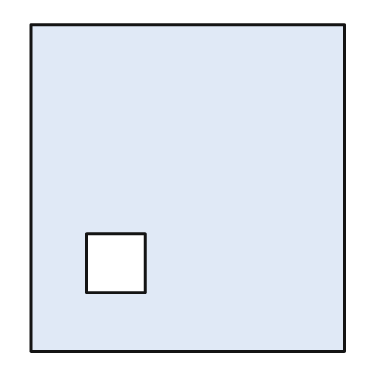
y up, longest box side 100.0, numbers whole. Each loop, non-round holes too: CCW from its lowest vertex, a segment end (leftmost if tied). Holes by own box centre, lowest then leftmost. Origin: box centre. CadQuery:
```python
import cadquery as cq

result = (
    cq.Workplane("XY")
    .moveTo(-48.0, -50.0)
    .lineTo(48.0, -50.0)
    .lineTo(48.0, 50.0)
    .lineTo(-48.0, 50.0)
    .close()
    .moveTo(-31.0, -32.0)
    .lineTo(-13.0, -32.0)
    .lineTo(-13.0, -14.0)
    .lineTo(-31.0, -14.0)
    .close()
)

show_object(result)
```